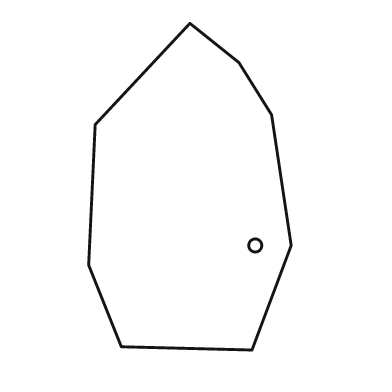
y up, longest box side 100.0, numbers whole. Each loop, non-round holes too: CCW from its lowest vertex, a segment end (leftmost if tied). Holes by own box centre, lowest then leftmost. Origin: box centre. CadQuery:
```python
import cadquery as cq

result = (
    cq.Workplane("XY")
    .moveTo(19.0, -50.0)
    .lineTo(31.0, -18.0)
    .lineTo(25.0, 22.0)
    .lineTo(15.0, 38.0)
    .lineTo(0.0, 50.0)
    .lineTo(-29.0, 19.0)
    .lineTo(-31.0, -24.0)
    .lineTo(-21.0, -49.0)
    .close()
    .moveTo(20.0, -18.0)
    .circle(2.0)
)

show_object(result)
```